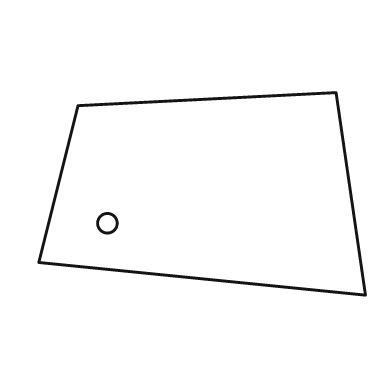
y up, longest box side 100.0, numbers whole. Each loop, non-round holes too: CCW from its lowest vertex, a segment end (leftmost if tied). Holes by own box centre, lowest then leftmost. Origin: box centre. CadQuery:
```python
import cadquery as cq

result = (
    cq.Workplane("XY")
    .moveTo(50.0, -31.0)
    .lineTo(41.0, 31.0)
    .lineTo(-38.0, 27.0)
    .lineTo(-50.0, -21.0)
    .close()
    .moveTo(-29.0, -9.0)
    .circle(3.0)
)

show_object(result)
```